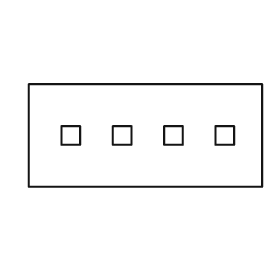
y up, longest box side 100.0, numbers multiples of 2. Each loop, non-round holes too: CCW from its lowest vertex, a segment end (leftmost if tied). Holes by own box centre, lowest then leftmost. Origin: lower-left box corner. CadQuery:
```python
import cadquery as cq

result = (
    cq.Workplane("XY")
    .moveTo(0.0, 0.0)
    .lineTo(100.0, 0.0)
    .lineTo(100.0, 44.0)
    .lineTo(0.0, 44.0)
    .close()
    .moveTo(14.0, 18.0)
    .lineTo(22.0, 18.0)
    .lineTo(22.0, 26.0)
    .lineTo(14.0, 26.0)
    .close()
    .moveTo(36.0, 18.0)
    .lineTo(44.0, 18.0)
    .lineTo(44.0, 26.0)
    .lineTo(36.0, 26.0)
    .close()
    .moveTo(58.0, 18.0)
    .lineTo(66.0, 18.0)
    .lineTo(66.0, 26.0)
    .lineTo(58.0, 26.0)
    .close()
    .moveTo(80.0, 18.0)
    .lineTo(88.0, 18.0)
    .lineTo(88.0, 26.0)
    .lineTo(80.0, 26.0)
    .close()
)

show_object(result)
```